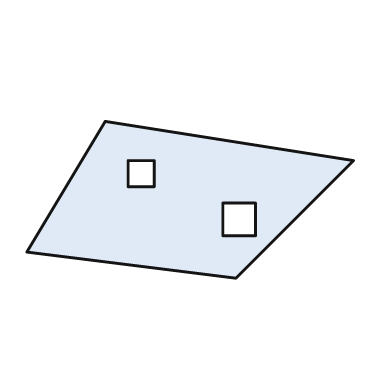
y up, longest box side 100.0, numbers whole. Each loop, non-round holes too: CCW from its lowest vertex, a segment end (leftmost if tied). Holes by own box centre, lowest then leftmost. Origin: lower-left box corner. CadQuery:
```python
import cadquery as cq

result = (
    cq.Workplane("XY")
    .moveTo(64.0, 0.0)
    .lineTo(100.0, 36.0)
    .lineTo(24.0, 48.0)
    .lineTo(0.0, 8.0)
    .close()
    .moveTo(60.0, 13.0)
    .lineTo(70.0, 13.0)
    .lineTo(70.0, 23.0)
    .lineTo(60.0, 23.0)
    .close()
    .moveTo(31.0, 28.0)
    .lineTo(39.0, 28.0)
    .lineTo(39.0, 36.0)
    .lineTo(31.0, 36.0)
    .close()
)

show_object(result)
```